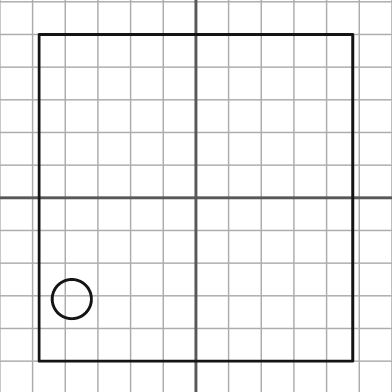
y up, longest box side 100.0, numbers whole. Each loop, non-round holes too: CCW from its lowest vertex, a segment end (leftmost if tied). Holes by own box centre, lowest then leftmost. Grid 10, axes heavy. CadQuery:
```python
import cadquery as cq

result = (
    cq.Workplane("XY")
    .moveTo(-48.0, -50.0)
    .lineTo(48.0, -50.0)
    .lineTo(48.0, 50.0)
    .lineTo(-48.0, 50.0)
    .close()
    .moveTo(-38.0, -31.0)
    .circle(6.0)
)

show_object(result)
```